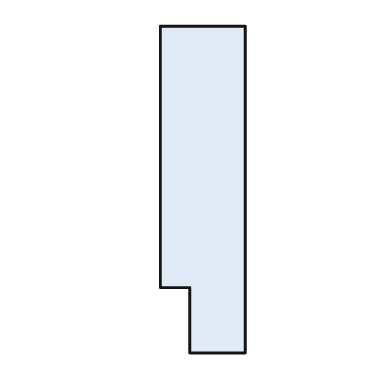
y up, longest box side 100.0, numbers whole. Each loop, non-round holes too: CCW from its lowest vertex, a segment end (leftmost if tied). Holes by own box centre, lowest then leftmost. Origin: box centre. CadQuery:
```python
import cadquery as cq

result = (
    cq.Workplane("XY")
    .moveTo(-4.0, -50.0)
    .lineTo(13.0, -50.0)
    .lineTo(13.0, 50.0)
    .lineTo(-13.0, 50.0)
    .lineTo(-13.0, -30.0)
    .lineTo(-4.0, -30.0)
    .close()
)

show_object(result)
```